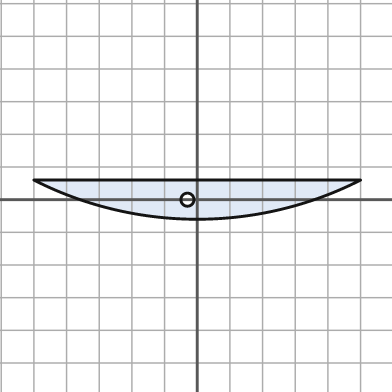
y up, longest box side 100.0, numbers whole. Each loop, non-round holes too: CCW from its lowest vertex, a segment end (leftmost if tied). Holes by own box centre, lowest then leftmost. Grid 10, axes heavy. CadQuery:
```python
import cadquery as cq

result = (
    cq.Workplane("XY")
    .moveTo(-50.0, 6.0)
    .threePointArc((0.0, -6.0), (50.0, 6.0))
    .close()
    .moveTo(-3.0, 0.0)
    .circle(2.0)
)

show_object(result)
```